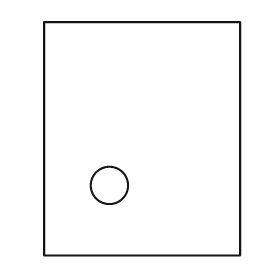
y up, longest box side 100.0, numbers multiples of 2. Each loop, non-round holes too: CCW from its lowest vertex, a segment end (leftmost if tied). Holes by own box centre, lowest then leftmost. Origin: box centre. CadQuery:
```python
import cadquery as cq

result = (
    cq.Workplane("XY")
    .moveTo(-42.0, -50.0)
    .lineTo(42.0, -50.0)
    .lineTo(42.0, 50.0)
    .lineTo(-42.0, 50.0)
    .close()
    .moveTo(-14.0, -20.0)
    .circle(8.0)
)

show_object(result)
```